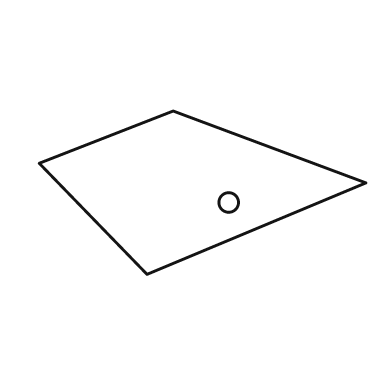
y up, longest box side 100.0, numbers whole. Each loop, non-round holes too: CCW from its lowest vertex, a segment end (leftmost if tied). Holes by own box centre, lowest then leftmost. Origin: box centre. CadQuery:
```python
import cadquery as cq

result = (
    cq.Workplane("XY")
    .moveTo(-17.0, -25.0)
    .lineTo(50.0, 3.0)
    .lineTo(-9.0, 25.0)
    .lineTo(-50.0, 9.0)
    .close()
    .moveTo(8.0, -3.0)
    .circle(3.0)
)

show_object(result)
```